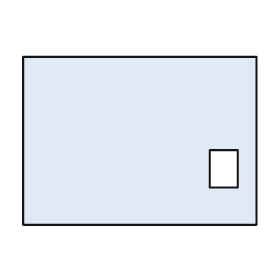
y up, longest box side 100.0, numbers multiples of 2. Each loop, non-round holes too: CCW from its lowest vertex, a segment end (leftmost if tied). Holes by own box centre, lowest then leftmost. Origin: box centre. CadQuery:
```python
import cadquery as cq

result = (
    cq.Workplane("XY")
    .moveTo(-50.0, -36.0)
    .lineTo(50.0, -36.0)
    .lineTo(50.0, 36.0)
    .lineTo(-50.0, 36.0)
    .close()
    .moveTo(30.0, -20.0)
    .lineTo(42.0, -20.0)
    .lineTo(42.0, -4.0)
    .lineTo(30.0, -4.0)
    .close()
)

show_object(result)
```